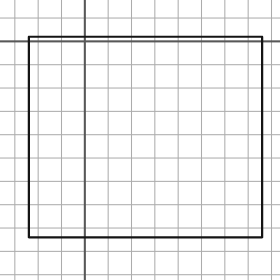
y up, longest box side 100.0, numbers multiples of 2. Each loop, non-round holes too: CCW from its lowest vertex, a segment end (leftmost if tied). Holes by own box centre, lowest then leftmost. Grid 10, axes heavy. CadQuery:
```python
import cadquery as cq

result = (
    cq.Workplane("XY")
    .moveTo(-24.0, -84.0)
    .lineTo(76.0, -84.0)
    .lineTo(76.0, 2.0)
    .lineTo(-24.0, 2.0)
    .close()
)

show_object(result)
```